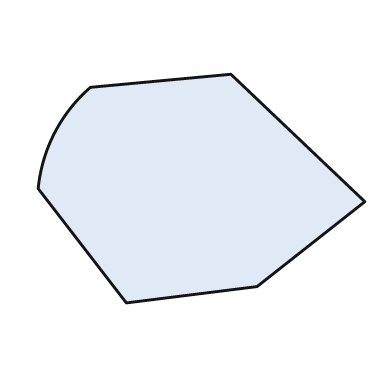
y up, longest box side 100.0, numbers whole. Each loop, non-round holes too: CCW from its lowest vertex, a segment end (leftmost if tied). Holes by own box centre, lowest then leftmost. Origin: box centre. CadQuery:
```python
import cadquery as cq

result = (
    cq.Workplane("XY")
    .moveTo(-23.0, -35.0)
    .lineTo(17.0, -30.0)
    .lineTo(50.0, -4.0)
    .lineTo(9.0, 35.0)
    .lineTo(-34.0, 31.0)
    .threePointArc((-45.0, 17.0), (-50.0, 0.0))
    .close()
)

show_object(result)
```